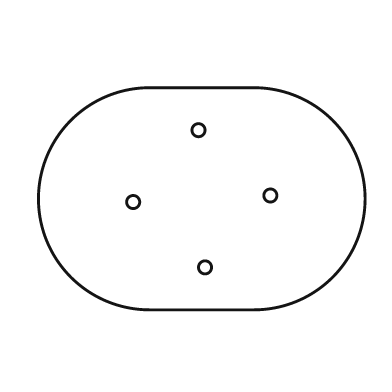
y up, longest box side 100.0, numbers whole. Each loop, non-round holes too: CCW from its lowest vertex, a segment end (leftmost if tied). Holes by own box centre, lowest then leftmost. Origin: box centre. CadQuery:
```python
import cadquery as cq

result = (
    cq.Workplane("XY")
    .moveTo(-16.0, -34.0)
    .lineTo(16.0, -34.0)
    .threePointArc((50.0, 0.0), (16.0, 34.0))
    .lineTo(-16.0, 34.0)
    .threePointArc((-50.0, 0.0), (-16.0, -34.0))
    .close()
    .moveTo(1.0, -21.0)
    .circle(2.0)
    .moveTo(-21.0, -1.0)
    .circle(2.0)
    .moveTo(21.0, 1.0)
    .circle(2.0)
    .moveTo(-1.0, 21.0)
    .circle(2.0)
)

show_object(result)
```